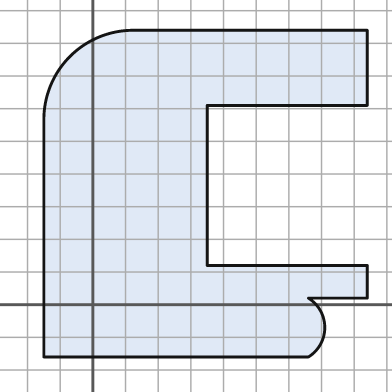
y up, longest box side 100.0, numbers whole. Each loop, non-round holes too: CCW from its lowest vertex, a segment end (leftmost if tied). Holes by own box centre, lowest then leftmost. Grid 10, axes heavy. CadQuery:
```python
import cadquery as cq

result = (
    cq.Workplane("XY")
    .moveTo(-15.0, -16.0)
    .lineTo(66.0, -16.0)
    .threePointArc((71.0, -7.0), (66.0, 2.0))
    .lineTo(84.0, 2.0)
    .lineTo(84.0, 12.0)
    .lineTo(35.0, 12.0)
    .lineTo(35.0, 61.0)
    .lineTo(84.0, 61.0)
    .lineTo(84.0, 84.0)
    .lineTo(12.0, 84.0)
    .threePointArc((-7.0, 76.0), (-15.0, 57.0))
    .close()
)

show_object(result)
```